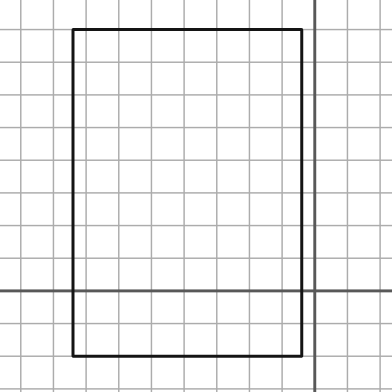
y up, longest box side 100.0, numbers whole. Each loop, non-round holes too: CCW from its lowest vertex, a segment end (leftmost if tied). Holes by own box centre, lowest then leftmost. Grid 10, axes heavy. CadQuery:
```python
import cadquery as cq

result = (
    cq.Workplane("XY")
    .moveTo(-74.0, -20.0)
    .lineTo(-4.0, -20.0)
    .lineTo(-4.0, 80.0)
    .lineTo(-74.0, 80.0)
    .close()
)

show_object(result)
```